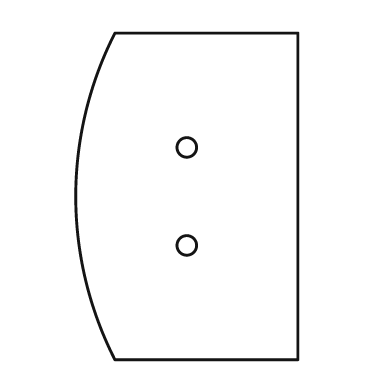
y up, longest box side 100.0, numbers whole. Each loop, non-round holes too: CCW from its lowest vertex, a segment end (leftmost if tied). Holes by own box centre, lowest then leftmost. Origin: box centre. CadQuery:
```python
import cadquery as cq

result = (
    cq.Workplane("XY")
    .moveTo(-22.0, -50.0)
    .lineTo(34.0, -50.0)
    .lineTo(34.0, 50.0)
    .lineTo(-22.0, 50.0)
    .threePointArc((-34.0, 0.0), (-22.0, -50.0))
    .close()
    .moveTo(0.0, -15.0)
    .circle(3.0)
    .moveTo(0.0, 15.0)
    .circle(3.0)
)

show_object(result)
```